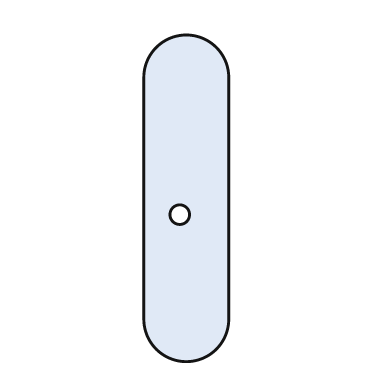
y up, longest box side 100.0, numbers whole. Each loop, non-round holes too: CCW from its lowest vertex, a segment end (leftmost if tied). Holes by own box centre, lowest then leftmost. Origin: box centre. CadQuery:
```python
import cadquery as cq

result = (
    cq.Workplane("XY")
    .moveTo(-13.0, -37.0)
    .threePointArc((0.0, -50.0), (13.0, -37.0))
    .lineTo(13.0, 37.0)
    .threePointArc((0.0, 50.0), (-13.0, 37.0))
    .close()
    .moveTo(-2.0, -5.0)
    .circle(3.0)
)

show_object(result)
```